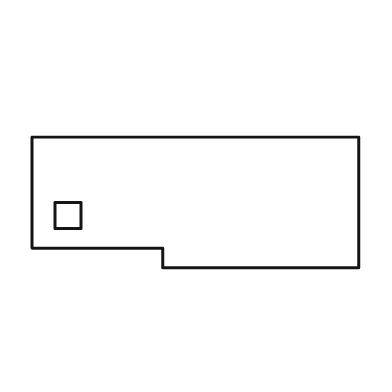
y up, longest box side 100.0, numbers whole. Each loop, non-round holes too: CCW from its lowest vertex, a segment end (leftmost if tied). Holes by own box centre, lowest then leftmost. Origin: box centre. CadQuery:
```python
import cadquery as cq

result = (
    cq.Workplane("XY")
    .moveTo(-10.0, -20.0)
    .lineTo(50.0, -20.0)
    .lineTo(50.0, 20.0)
    .lineTo(-50.0, 20.0)
    .lineTo(-50.0, -14.0)
    .lineTo(-10.0, -14.0)
    .close()
    .moveTo(-43.0, -8.0)
    .lineTo(-35.0, -8.0)
    .lineTo(-35.0, 0.0)
    .lineTo(-43.0, 0.0)
    .close()
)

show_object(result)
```